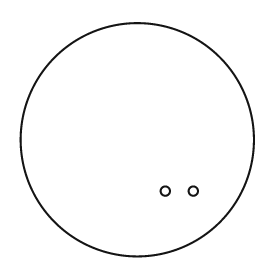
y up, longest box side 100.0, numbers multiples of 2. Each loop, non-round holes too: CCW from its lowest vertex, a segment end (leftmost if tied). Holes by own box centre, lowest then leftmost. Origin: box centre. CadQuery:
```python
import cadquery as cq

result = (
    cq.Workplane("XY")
    .moveTo(0.0, 0.0)
    .circle(50.0)
    .moveTo(12.0, -22.0)
    .circle(2.0)
    .moveTo(24.0, -22.0)
    .circle(2.0)
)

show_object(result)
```